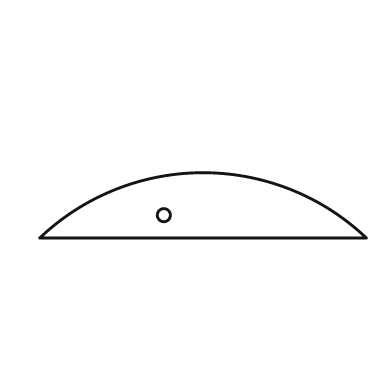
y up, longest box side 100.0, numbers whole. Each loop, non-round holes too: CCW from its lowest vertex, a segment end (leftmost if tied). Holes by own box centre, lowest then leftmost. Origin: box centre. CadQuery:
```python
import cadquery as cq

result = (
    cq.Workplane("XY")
    .moveTo(-50.0, -10.0)
    .lineTo(50.0, -10.0)
    .threePointArc((0.0, 10.0), (-50.0, -10.0))
    .close()
    .moveTo(-12.0, -3.0)
    .circle(2.0)
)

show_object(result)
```